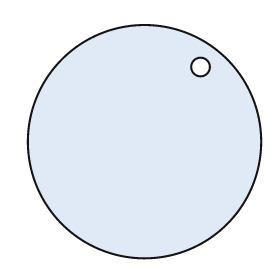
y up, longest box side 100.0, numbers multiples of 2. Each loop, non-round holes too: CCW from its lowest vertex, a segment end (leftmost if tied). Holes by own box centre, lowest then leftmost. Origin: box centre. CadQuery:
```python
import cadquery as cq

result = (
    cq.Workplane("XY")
    .moveTo(0.0, 0.0)
    .circle(50.0)
    .moveTo(24.0, 32.0)
    .circle(4.0)
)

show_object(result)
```